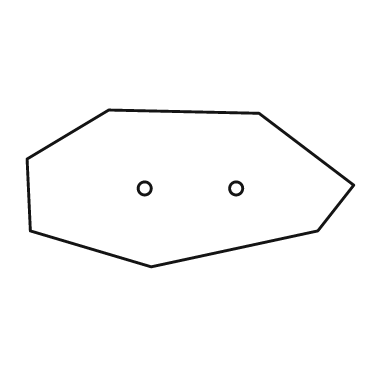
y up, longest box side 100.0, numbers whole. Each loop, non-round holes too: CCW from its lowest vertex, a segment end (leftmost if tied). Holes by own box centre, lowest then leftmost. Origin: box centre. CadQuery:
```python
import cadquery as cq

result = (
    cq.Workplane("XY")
    .moveTo(-12.0, -24.0)
    .lineTo(39.0, -13.0)
    .lineTo(50.0, 1.0)
    .lineTo(21.0, 23.0)
    .lineTo(-25.0, 24.0)
    .lineTo(-50.0, 9.0)
    .lineTo(-49.0, -13.0)
    .close()
    .moveTo(-14.0, 0.0)
    .circle(2.0)
    .moveTo(14.0, 0.0)
    .circle(2.0)
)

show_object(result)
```